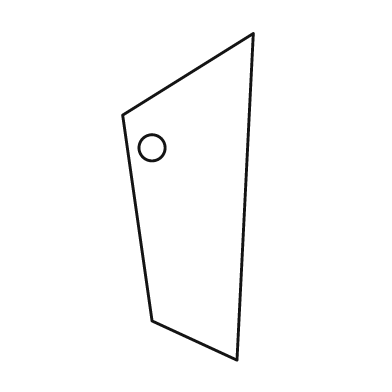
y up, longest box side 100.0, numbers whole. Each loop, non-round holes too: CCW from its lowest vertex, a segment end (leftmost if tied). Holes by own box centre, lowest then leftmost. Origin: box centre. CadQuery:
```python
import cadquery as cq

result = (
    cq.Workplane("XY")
    .moveTo(15.0, -50.0)
    .lineTo(20.0, 50.0)
    .lineTo(-20.0, 25.0)
    .lineTo(-11.0, -38.0)
    .close()
    .moveTo(-11.0, 15.0)
    .circle(4.0)
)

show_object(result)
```